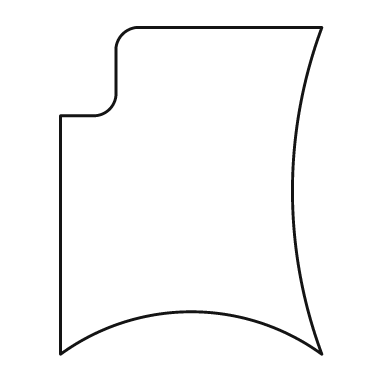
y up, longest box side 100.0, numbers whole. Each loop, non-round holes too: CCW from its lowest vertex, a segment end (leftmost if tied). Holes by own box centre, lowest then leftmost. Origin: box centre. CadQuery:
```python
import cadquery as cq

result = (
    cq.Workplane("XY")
    .moveTo(-40.0, -50.0)
    .threePointArc((0.0, -37.0), (40.0, -50.0))
    .threePointArc((31.0, 0.0), (40.0, 50.0))
    .lineTo(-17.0, 50.0)
    .threePointArc((-21.0, 48.0), (-23.0, 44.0))
    .lineTo(-23.0, 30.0)
    .threePointArc((-25.0, 25.0), (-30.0, 23.0))
    .lineTo(-40.0, 23.0)
    .close()
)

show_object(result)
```